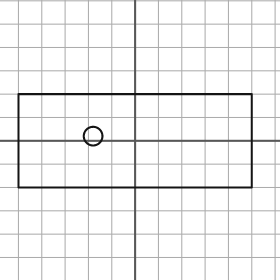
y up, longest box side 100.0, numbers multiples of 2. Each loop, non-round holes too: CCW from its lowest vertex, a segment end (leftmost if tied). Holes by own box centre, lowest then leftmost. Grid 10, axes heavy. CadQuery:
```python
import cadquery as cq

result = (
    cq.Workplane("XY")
    .moveTo(-50.0, -20.0)
    .lineTo(50.0, -20.0)
    .lineTo(50.0, 20.0)
    .lineTo(-50.0, 20.0)
    .close()
    .moveTo(-18.0, 2.0)
    .circle(4.0)
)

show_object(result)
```